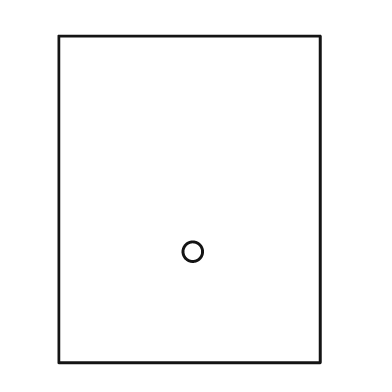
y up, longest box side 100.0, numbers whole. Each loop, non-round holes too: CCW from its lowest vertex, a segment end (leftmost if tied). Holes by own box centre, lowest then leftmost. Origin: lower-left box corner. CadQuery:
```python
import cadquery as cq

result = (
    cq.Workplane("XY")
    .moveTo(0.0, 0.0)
    .lineTo(80.0, 0.0)
    .lineTo(80.0, 100.0)
    .lineTo(0.0, 100.0)
    .close()
    .moveTo(41.0, 34.0)
    .circle(3.0)
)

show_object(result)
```